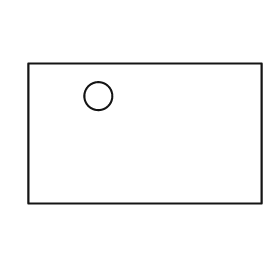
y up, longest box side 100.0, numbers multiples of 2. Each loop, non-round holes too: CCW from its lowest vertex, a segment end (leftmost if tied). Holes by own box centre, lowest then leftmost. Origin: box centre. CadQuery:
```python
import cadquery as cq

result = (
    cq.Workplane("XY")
    .moveTo(-50.0, -30.0)
    .lineTo(50.0, -30.0)
    .lineTo(50.0, 30.0)
    .lineTo(-50.0, 30.0)
    .close()
    .moveTo(-20.0, 16.0)
    .circle(6.0)
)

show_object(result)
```